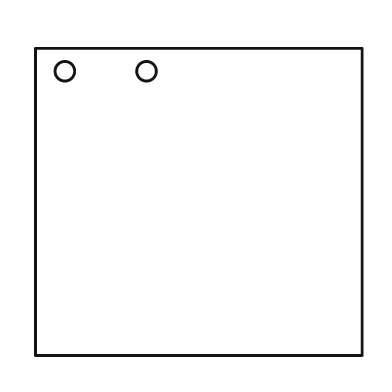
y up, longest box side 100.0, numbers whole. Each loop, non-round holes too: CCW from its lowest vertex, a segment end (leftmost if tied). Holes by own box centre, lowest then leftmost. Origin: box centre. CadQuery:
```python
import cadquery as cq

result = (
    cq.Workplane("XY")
    .moveTo(-50.0, -47.0)
    .lineTo(50.0, -47.0)
    .lineTo(50.0, 47.0)
    .lineTo(-50.0, 47.0)
    .close()
    .moveTo(-41.0, 40.0)
    .circle(3.0)
    .moveTo(-16.0, 40.0)
    .circle(3.0)
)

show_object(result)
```